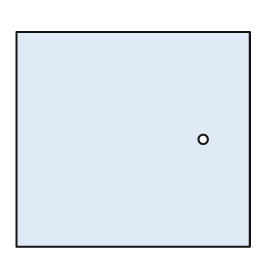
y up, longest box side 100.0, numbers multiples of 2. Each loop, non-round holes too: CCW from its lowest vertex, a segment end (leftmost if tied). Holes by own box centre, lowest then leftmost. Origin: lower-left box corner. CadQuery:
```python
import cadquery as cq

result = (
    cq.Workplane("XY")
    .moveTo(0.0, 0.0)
    .lineTo(100.0, 0.0)
    .lineTo(100.0, 92.0)
    .lineTo(0.0, 92.0)
    .close()
    .moveTo(80.0, 46.0)
    .circle(2.0)
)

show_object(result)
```